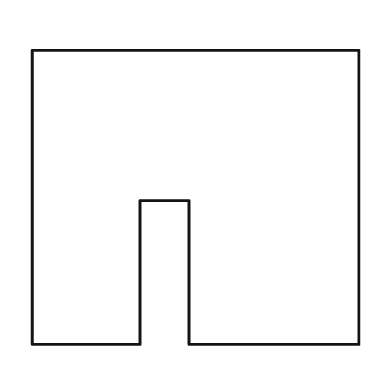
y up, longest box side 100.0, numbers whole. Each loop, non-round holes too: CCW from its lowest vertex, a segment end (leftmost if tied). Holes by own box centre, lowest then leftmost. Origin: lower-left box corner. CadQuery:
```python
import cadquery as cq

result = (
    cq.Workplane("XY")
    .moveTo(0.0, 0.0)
    .lineTo(33.0, 0.0)
    .lineTo(33.0, 44.0)
    .lineTo(48.0, 44.0)
    .lineTo(48.0, 0.0)
    .lineTo(100.0, 0.0)
    .lineTo(100.0, 90.0)
    .lineTo(0.0, 90.0)
    .close()
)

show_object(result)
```